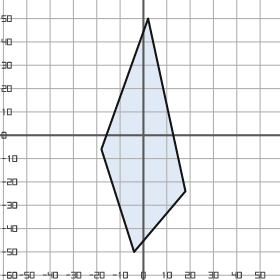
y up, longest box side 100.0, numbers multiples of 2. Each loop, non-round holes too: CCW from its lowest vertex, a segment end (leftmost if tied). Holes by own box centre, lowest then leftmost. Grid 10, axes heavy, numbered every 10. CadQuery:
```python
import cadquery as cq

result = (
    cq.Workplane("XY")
    .moveTo(-4.0, -50.0)
    .lineTo(18.0, -24.0)
    .lineTo(2.0, 50.0)
    .lineTo(-18.0, -6.0)
    .close()
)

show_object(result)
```